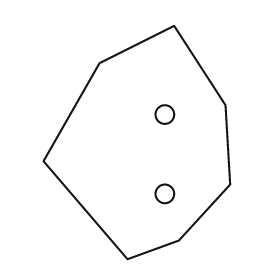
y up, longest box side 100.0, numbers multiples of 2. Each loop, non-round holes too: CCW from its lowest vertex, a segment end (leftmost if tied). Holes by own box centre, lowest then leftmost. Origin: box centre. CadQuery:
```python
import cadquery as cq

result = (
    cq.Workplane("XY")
    .moveTo(-4.0, -50.0)
    .lineTo(18.0, -42.0)
    .lineTo(40.0, -18.0)
    .lineTo(38.0, 16.0)
    .lineTo(16.0, 50.0)
    .lineTo(-16.0, 34.0)
    .lineTo(-40.0, -8.0)
    .close()
    .moveTo(12.0, -22.0)
    .circle(4.0)
    .moveTo(12.0, 12.0)
    .circle(4.0)
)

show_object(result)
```